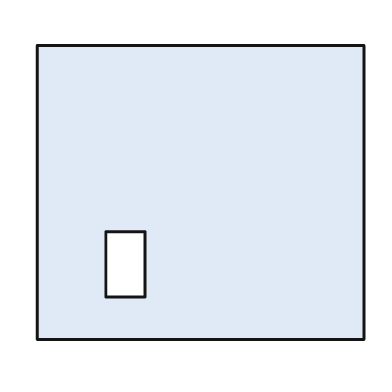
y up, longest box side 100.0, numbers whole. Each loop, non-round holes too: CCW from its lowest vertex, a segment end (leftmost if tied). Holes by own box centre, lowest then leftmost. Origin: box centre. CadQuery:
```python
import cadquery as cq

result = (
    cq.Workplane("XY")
    .moveTo(-50.0, -45.0)
    .lineTo(50.0, -45.0)
    .lineTo(50.0, 45.0)
    .lineTo(-50.0, 45.0)
    .close()
    .moveTo(-29.0, -32.0)
    .lineTo(-17.0, -32.0)
    .lineTo(-17.0, -12.0)
    .lineTo(-29.0, -12.0)
    .close()
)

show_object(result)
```